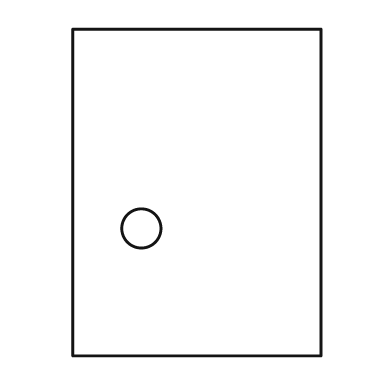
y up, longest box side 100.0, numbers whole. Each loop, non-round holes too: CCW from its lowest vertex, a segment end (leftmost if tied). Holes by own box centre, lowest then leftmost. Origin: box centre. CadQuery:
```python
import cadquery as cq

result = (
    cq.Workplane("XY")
    .moveTo(-38.0, -50.0)
    .lineTo(38.0, -50.0)
    .lineTo(38.0, 50.0)
    .lineTo(-38.0, 50.0)
    .close()
    .moveTo(-17.0, -11.0)
    .circle(6.0)
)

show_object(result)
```